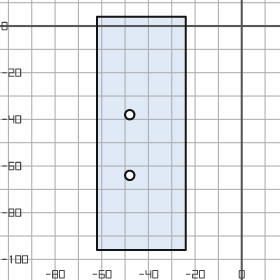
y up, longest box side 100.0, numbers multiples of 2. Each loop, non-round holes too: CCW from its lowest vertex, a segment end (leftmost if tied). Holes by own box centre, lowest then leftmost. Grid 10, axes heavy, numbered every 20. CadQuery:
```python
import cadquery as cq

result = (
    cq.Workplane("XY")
    .moveTo(-62.0, -96.0)
    .lineTo(-24.0, -96.0)
    .lineTo(-24.0, 4.0)
    .lineTo(-62.0, 4.0)
    .close()
    .moveTo(-48.0, -64.0)
    .circle(2.0)
    .moveTo(-48.0, -38.0)
    .circle(2.0)
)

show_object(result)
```